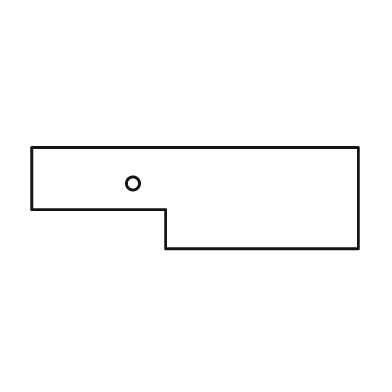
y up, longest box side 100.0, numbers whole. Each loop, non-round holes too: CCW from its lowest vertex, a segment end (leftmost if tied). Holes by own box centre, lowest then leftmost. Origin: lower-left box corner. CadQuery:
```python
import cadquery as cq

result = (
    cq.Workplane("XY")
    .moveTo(41.0, 0.0)
    .lineTo(100.0, 0.0)
    .lineTo(100.0, 31.0)
    .lineTo(0.0, 31.0)
    .lineTo(0.0, 12.0)
    .lineTo(41.0, 12.0)
    .close()
    .moveTo(31.0, 20.0)
    .circle(2.0)
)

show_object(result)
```